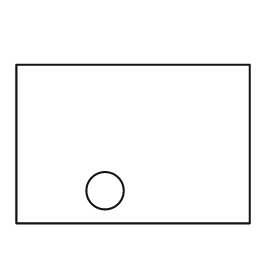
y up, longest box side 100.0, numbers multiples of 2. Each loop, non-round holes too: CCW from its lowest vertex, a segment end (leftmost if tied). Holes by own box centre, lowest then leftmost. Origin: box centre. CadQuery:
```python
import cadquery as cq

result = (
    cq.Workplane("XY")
    .moveTo(-50.0, -34.0)
    .lineTo(50.0, -34.0)
    .lineTo(50.0, 34.0)
    .lineTo(-50.0, 34.0)
    .close()
    .moveTo(-12.0, -20.0)
    .circle(8.0)
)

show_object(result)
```